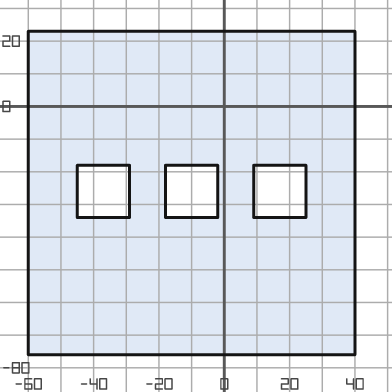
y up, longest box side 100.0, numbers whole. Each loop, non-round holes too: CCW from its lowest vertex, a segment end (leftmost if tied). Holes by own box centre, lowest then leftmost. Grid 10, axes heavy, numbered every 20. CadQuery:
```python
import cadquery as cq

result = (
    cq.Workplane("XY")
    .moveTo(-60.0, -76.0)
    .lineTo(40.0, -76.0)
    .lineTo(40.0, 23.0)
    .lineTo(-60.0, 23.0)
    .close()
    .moveTo(-45.0, -34.0)
    .lineTo(-29.0, -34.0)
    .lineTo(-29.0, -18.0)
    .lineTo(-45.0, -18.0)
    .close()
    .moveTo(-18.0, -34.0)
    .lineTo(-2.0, -34.0)
    .lineTo(-2.0, -18.0)
    .lineTo(-18.0, -18.0)
    .close()
    .moveTo(9.0, -34.0)
    .lineTo(25.0, -34.0)
    .lineTo(25.0, -18.0)
    .lineTo(9.0, -18.0)
    .close()
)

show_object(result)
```